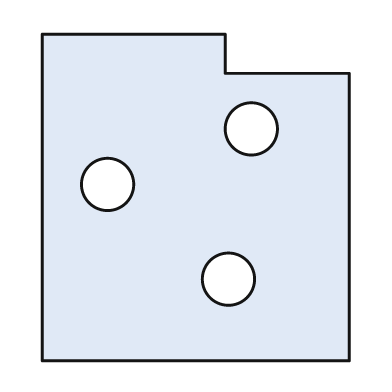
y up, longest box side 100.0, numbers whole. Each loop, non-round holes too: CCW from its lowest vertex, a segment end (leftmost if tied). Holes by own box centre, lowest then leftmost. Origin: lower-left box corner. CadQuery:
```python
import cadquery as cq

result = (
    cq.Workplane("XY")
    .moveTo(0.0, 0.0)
    .lineTo(94.0, 0.0)
    .lineTo(94.0, 88.0)
    .lineTo(56.0, 88.0)
    .lineTo(56.0, 100.0)
    .lineTo(0.0, 100.0)
    .close()
    .moveTo(57.0, 25.0)
    .circle(8.0)
    .moveTo(20.0, 54.0)
    .circle(8.0)
    .moveTo(64.0, 71.0)
    .circle(8.0)
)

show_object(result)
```